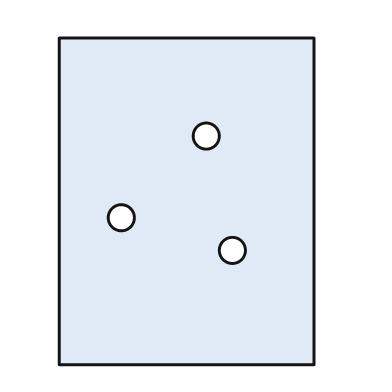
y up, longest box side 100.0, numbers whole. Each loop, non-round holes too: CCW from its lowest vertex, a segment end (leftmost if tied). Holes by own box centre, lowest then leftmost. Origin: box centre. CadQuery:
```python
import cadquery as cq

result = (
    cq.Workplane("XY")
    .moveTo(-39.0, -50.0)
    .lineTo(39.0, -50.0)
    .lineTo(39.0, 50.0)
    .lineTo(-39.0, 50.0)
    .close()
    .moveTo(14.0, -15.0)
    .circle(4.0)
    .moveTo(-20.0, -5.0)
    .circle(4.0)
    .moveTo(6.0, 20.0)
    .circle(4.0)
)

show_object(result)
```